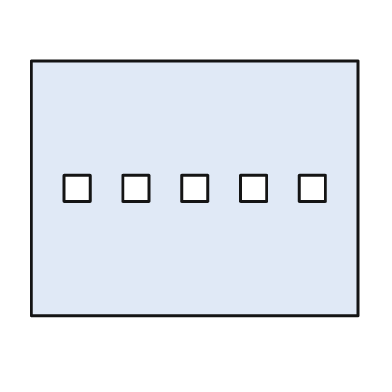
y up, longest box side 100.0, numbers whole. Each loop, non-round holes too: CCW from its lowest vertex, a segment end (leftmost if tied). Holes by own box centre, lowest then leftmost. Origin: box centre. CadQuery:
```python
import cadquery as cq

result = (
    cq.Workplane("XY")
    .moveTo(-50.0, -39.0)
    .lineTo(50.0, -39.0)
    .lineTo(50.0, 39.0)
    .lineTo(-50.0, 39.0)
    .close()
    .moveTo(-40.0, -4.0)
    .lineTo(-32.0, -4.0)
    .lineTo(-32.0, 4.0)
    .lineTo(-40.0, 4.0)
    .close()
    .moveTo(-22.0, -4.0)
    .lineTo(-14.0, -4.0)
    .lineTo(-14.0, 4.0)
    .lineTo(-22.0, 4.0)
    .close()
    .moveTo(-4.0, -4.0)
    .lineTo(4.0, -4.0)
    .lineTo(4.0, 4.0)
    .lineTo(-4.0, 4.0)
    .close()
    .moveTo(14.0, -4.0)
    .lineTo(22.0, -4.0)
    .lineTo(22.0, 4.0)
    .lineTo(14.0, 4.0)
    .close()
    .moveTo(32.0, -4.0)
    .lineTo(40.0, -4.0)
    .lineTo(40.0, 4.0)
    .lineTo(32.0, 4.0)
    .close()
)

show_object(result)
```